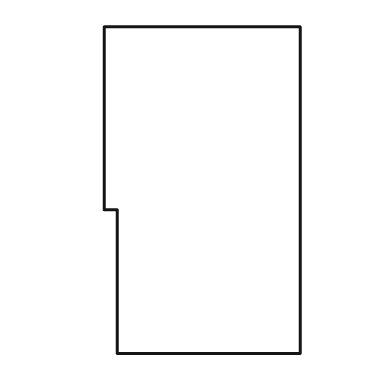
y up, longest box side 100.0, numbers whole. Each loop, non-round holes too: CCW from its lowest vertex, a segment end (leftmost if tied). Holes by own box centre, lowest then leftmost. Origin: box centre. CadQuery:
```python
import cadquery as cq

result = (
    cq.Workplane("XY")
    .moveTo(-26.0, -50.0)
    .lineTo(30.0, -50.0)
    .lineTo(30.0, 50.0)
    .lineTo(-30.0, 50.0)
    .lineTo(-30.0, -6.0)
    .lineTo(-26.0, -6.0)
    .close()
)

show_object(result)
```